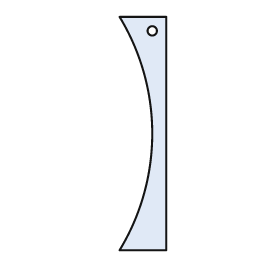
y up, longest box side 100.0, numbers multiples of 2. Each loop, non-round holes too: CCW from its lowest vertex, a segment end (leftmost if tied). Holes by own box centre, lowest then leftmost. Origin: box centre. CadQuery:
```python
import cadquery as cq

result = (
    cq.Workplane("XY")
    .moveTo(-10.0, -50.0)
    .lineTo(10.0, -50.0)
    .lineTo(10.0, 50.0)
    .lineTo(-10.0, 50.0)
    .threePointArc((4.0, 0.0), (-10.0, -50.0))
    .close()
    .moveTo(4.0, 44.0)
    .circle(2.0)
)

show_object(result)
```